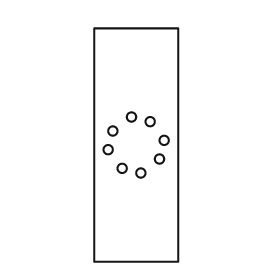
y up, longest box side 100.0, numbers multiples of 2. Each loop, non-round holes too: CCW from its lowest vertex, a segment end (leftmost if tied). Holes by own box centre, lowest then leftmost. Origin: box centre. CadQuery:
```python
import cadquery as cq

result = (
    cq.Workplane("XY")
    .moveTo(-18.0, -50.0)
    .lineTo(18.0, -50.0)
    .lineTo(18.0, 50.0)
    .lineTo(-18.0, 50.0)
    .close()
    .moveTo(2.0, -12.0)
    .circle(2.0)
    .moveTo(-6.0, -10.0)
    .circle(2.0)
    .moveTo(10.0, -6.0)
    .circle(2.0)
    .moveTo(-12.0, -2.0)
    .circle(2.0)
    .moveTo(12.0, 2.0)
    .circle(2.0)
    .moveTo(-10.0, 6.0)
    .circle(2.0)
    .moveTo(6.0, 10.0)
    .circle(2.0)
    .moveTo(-2.0, 12.0)
    .circle(2.0)
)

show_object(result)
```